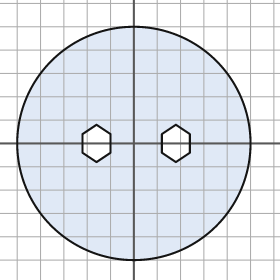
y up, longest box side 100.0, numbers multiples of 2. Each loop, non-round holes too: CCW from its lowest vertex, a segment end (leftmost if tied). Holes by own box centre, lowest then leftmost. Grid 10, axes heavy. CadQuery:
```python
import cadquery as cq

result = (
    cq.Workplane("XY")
    .moveTo(0.0, 0.0)
    .circle(50.0)
    .moveTo(-16.0, -8.0)
    .lineTo(-10.0, -4.0)
    .lineTo(-10.0, 4.0)
    .lineTo(-16.0, 8.0)
    .lineTo(-22.0, 4.0)
    .lineTo(-22.0, -4.0)
    .close()
    .moveTo(18.0, -8.0)
    .lineTo(24.0, -4.0)
    .lineTo(24.0, 4.0)
    .lineTo(18.0, 8.0)
    .lineTo(12.0, 4.0)
    .lineTo(12.0, -4.0)
    .close()
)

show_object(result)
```